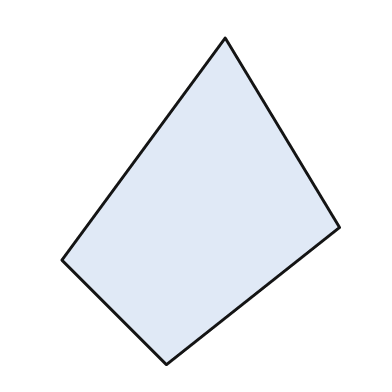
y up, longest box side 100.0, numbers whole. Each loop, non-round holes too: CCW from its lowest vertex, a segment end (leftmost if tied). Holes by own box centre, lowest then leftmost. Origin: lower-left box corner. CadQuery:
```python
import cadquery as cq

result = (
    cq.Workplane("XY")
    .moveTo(32.0, 0.0)
    .lineTo(85.0, 42.0)
    .lineTo(50.0, 100.0)
    .lineTo(0.0, 32.0)
    .close()
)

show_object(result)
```